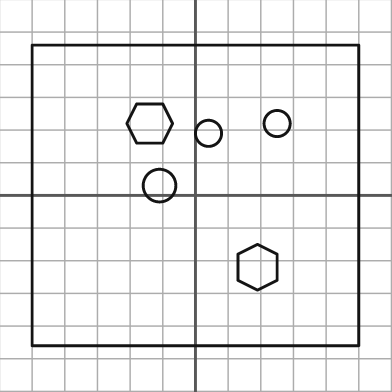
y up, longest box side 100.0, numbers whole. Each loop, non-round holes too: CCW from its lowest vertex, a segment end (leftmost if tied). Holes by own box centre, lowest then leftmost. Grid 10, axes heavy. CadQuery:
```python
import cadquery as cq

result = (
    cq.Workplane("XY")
    .moveTo(-50.0, -46.0)
    .lineTo(50.0, -46.0)
    .lineTo(50.0, 46.0)
    .lineTo(-50.0, 46.0)
    .close()
    .moveTo(19.0, -29.0)
    .lineTo(25.0, -26.0)
    .lineTo(25.0, -18.0)
    .lineTo(19.0, -15.0)
    .lineTo(13.0, -18.0)
    .lineTo(13.0, -26.0)
    .close()
    .moveTo(-11.0, 3.0)
    .circle(5.0)
    .moveTo(4.0, 19.0)
    .circle(4.0)
    .moveTo(-18.0, 16.0)
    .lineTo(-10.0, 16.0)
    .lineTo(-7.0, 22.0)
    .lineTo(-10.0, 28.0)
    .lineTo(-18.0, 28.0)
    .lineTo(-21.0, 22.0)
    .close()
    .moveTo(25.0, 22.0)
    .circle(4.0)
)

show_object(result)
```